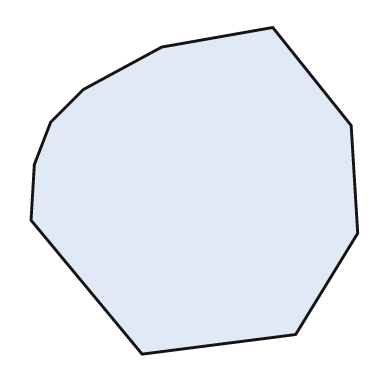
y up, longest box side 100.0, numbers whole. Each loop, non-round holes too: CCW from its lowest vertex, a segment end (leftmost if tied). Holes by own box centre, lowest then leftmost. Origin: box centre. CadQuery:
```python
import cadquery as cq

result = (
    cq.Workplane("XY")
    .moveTo(-16.0, -50.0)
    .lineTo(31.0, -44.0)
    .lineTo(50.0, -13.0)
    .lineTo(48.0, 20.0)
    .lineTo(24.0, 50.0)
    .lineTo(-10.0, 44.0)
    .lineTo(-34.0, 31.0)
    .lineTo(-44.0, 21.0)
    .lineTo(-49.0, 8.0)
    .lineTo(-50.0, -9.0)
    .close()
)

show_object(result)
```